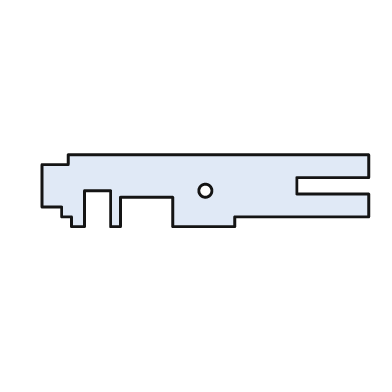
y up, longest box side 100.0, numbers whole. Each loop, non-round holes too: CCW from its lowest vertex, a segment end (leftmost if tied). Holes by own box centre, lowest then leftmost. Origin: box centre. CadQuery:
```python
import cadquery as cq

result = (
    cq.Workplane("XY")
    .moveTo(-41.0, -11.0)
    .lineTo(-37.0, -11.0)
    .lineTo(-37.0, 0.0)
    .lineTo(-29.0, 0.0)
    .lineTo(-29.0, -11.0)
    .lineTo(-26.0, -11.0)
    .lineTo(-26.0, -2.0)
    .lineTo(-10.0, -2.0)
    .lineTo(-10.0, -11.0)
    .lineTo(9.0, -11.0)
    .lineTo(9.0, -8.0)
    .lineTo(50.0, -8.0)
    .lineTo(50.0, -1.0)
    .lineTo(28.0, -1.0)
    .lineTo(28.0, 4.0)
    .lineTo(50.0, 4.0)
    .lineTo(50.0, 11.0)
    .lineTo(-42.0, 11.0)
    .lineTo(-42.0, 8.0)
    .lineTo(-50.0, 8.0)
    .lineTo(-50.0, -5.0)
    .lineTo(-44.0, -5.0)
    .lineTo(-44.0, -8.0)
    .lineTo(-41.0, -8.0)
    .close()
    .moveTo(0.0, 0.0)
    .circle(2.0)
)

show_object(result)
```